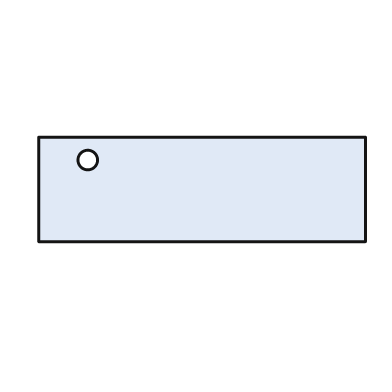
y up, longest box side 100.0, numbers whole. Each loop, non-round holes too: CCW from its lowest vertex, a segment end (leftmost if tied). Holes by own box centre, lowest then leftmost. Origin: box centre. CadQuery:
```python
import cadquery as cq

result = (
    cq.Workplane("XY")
    .moveTo(-50.0, -16.0)
    .lineTo(50.0, -16.0)
    .lineTo(50.0, 16.0)
    .lineTo(-50.0, 16.0)
    .close()
    .moveTo(-35.0, 9.0)
    .circle(3.0)
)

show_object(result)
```